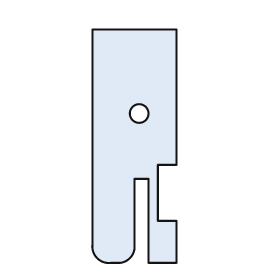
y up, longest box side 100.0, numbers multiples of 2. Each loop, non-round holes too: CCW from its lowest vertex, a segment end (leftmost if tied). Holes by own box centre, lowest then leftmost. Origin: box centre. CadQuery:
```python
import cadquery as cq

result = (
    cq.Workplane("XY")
    .moveTo(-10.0, -50.0)
    .lineTo(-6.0, -50.0)
    .threePointArc((-2.0, -48.0), (0.0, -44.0))
    .lineTo(0.0, -14.0)
    .lineTo(6.0, -14.0)
    .lineTo(6.0, -50.0)
    .lineTo(18.0, -50.0)
    .lineTo(18.0, -32.0)
    .lineTo(10.0, -32.0)
    .lineTo(10.0, -8.0)
    .lineTo(18.0, -8.0)
    .lineTo(18.0, 50.0)
    .lineTo(-18.0, 50.0)
    .lineTo(-18.0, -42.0)
    .threePointArc((-16.0, -48.0), (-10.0, -50.0))
    .close()
    .moveTo(2.0, 14.0)
    .circle(4.0)
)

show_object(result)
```